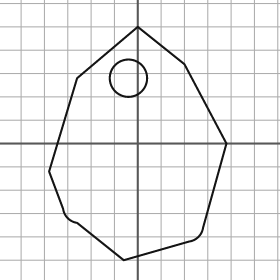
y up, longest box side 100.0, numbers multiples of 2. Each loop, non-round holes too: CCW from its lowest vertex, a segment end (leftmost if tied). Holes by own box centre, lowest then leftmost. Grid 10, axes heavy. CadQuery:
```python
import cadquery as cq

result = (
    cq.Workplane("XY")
    .moveTo(-6.0, -50.0)
    .lineTo(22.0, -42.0)
    .threePointArc((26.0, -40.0), (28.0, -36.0))
    .lineTo(38.0, 0.0)
    .lineTo(20.0, 34.0)
    .lineTo(0.0, 50.0)
    .lineTo(-26.0, 28.0)
    .lineTo(-38.0, -12.0)
    .lineTo(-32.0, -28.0)
    .threePointArc((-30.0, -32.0), (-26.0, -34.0))
    .close()
    .moveTo(-4.0, 28.0)
    .circle(8.0)
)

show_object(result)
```